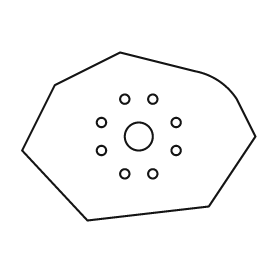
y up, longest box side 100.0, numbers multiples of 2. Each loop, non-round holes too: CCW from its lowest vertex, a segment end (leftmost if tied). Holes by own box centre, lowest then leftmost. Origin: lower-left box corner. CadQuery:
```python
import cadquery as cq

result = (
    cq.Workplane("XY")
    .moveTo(28.0, 0.0)
    .lineTo(80.0, 6.0)
    .lineTo(100.0, 36.0)
    .lineTo(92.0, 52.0)
    .threePointArc((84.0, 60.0), (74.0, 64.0))
    .lineTo(42.0, 72.0)
    .lineTo(14.0, 58.0)
    .lineTo(0.0, 30.0)
    .close()
    .moveTo(44.0, 20.0)
    .circle(2.0)
    .moveTo(56.0, 20.0)
    .circle(2.0)
    .moveTo(34.0, 30.0)
    .circle(2.0)
    .moveTo(66.0, 30.0)
    .circle(2.0)
    .moveTo(50.0, 36.0)
    .circle(6.0)
    .moveTo(34.0, 42.0)
    .circle(2.0)
    .moveTo(66.0, 42.0)
    .circle(2.0)
    .moveTo(44.0, 52.0)
    .circle(2.0)
    .moveTo(56.0, 52.0)
    .circle(2.0)
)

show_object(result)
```